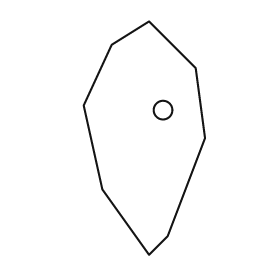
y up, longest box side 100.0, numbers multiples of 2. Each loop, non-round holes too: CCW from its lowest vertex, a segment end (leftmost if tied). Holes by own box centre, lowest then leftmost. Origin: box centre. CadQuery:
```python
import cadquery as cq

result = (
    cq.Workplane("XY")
    .moveTo(2.0, -50.0)
    .lineTo(10.0, -42.0)
    .lineTo(26.0, 0.0)
    .lineTo(22.0, 30.0)
    .lineTo(2.0, 50.0)
    .lineTo(-14.0, 40.0)
    .lineTo(-26.0, 14.0)
    .lineTo(-18.0, -22.0)
    .close()
    .moveTo(8.0, 12.0)
    .circle(4.0)
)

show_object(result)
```